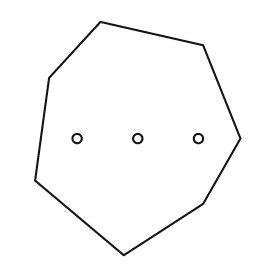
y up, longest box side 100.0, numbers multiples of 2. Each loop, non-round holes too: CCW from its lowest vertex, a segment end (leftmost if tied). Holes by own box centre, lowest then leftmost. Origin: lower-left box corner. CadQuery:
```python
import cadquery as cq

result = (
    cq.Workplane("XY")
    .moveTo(38.0, 0.0)
    .lineTo(72.0, 22.0)
    .lineTo(88.0, 50.0)
    .lineTo(72.0, 90.0)
    .lineTo(28.0, 100.0)
    .lineTo(6.0, 76.0)
    .lineTo(0.0, 32.0)
    .close()
    .moveTo(18.0, 50.0)
    .circle(2.0)
    .moveTo(44.0, 50.0)
    .circle(2.0)
    .moveTo(70.0, 50.0)
    .circle(2.0)
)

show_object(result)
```